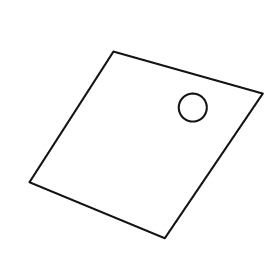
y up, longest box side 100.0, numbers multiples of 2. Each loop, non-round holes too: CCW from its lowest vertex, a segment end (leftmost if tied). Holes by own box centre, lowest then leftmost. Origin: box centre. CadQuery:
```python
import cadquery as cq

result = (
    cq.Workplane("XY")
    .moveTo(8.0, -40.0)
    .lineTo(50.0, 22.0)
    .lineTo(-14.0, 40.0)
    .lineTo(-50.0, -16.0)
    .close()
    .moveTo(20.0, 16.0)
    .circle(6.0)
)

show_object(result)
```